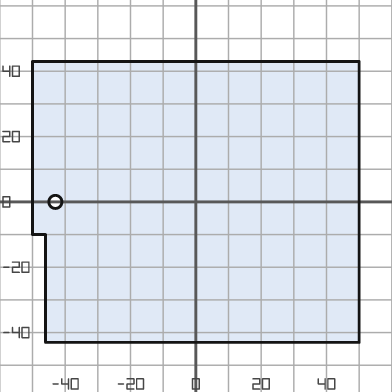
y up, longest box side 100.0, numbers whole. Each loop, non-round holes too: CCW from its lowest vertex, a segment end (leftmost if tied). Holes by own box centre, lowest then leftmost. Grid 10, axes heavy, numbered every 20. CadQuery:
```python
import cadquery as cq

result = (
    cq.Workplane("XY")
    .moveTo(-46.0, -43.0)
    .lineTo(50.0, -43.0)
    .lineTo(50.0, 43.0)
    .lineTo(-50.0, 43.0)
    .lineTo(-50.0, -10.0)
    .lineTo(-46.0, -10.0)
    .close()
    .moveTo(-43.0, 0.0)
    .circle(2.0)
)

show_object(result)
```